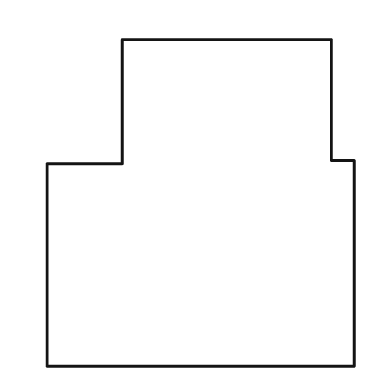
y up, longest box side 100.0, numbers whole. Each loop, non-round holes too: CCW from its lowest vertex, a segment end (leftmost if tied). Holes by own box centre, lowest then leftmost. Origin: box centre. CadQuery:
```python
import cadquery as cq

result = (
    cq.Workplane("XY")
    .moveTo(-47.0, -50.0)
    .lineTo(47.0, -50.0)
    .lineTo(47.0, 13.0)
    .lineTo(40.0, 13.0)
    .lineTo(40.0, 50.0)
    .lineTo(-24.0, 50.0)
    .lineTo(-24.0, 12.0)
    .lineTo(-47.0, 12.0)
    .close()
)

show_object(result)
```